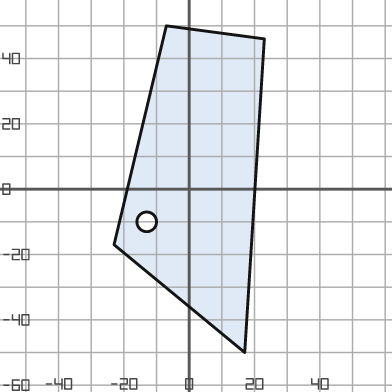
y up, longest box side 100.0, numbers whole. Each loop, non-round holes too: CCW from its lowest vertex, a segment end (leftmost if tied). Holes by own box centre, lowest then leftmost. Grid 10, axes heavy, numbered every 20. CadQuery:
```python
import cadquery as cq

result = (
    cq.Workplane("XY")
    .moveTo(17.0, -50.0)
    .lineTo(23.0, 46.0)
    .lineTo(-7.0, 50.0)
    .lineTo(-23.0, -17.0)
    .close()
    .moveTo(-13.0, -10.0)
    .circle(3.0)
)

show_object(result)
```